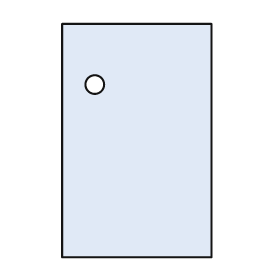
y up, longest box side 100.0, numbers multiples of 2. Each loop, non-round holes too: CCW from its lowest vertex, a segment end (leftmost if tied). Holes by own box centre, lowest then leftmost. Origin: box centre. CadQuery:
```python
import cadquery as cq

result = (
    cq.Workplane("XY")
    .moveTo(-32.0, -50.0)
    .lineTo(32.0, -50.0)
    .lineTo(32.0, 50.0)
    .lineTo(-32.0, 50.0)
    .close()
    .moveTo(-18.0, 24.0)
    .circle(4.0)
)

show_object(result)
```